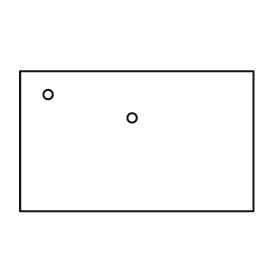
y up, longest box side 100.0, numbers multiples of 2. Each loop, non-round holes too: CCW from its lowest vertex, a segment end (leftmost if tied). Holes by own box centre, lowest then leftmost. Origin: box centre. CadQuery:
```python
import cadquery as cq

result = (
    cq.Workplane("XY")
    .moveTo(-50.0, -30.0)
    .lineTo(50.0, -30.0)
    .lineTo(50.0, 30.0)
    .lineTo(-50.0, 30.0)
    .close()
    .moveTo(-2.0, 10.0)
    .circle(2.0)
    .moveTo(-38.0, 20.0)
    .circle(2.0)
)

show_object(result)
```